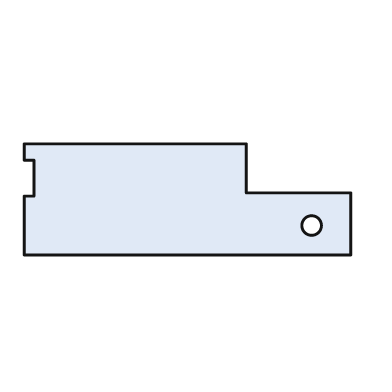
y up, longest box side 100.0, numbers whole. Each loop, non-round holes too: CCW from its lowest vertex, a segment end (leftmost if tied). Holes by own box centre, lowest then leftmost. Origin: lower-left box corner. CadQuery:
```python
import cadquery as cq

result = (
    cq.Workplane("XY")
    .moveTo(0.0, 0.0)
    .lineTo(100.0, 0.0)
    .lineTo(100.0, 19.0)
    .lineTo(68.0, 19.0)
    .lineTo(68.0, 34.0)
    .lineTo(0.0, 34.0)
    .lineTo(0.0, 29.0)
    .lineTo(3.0, 29.0)
    .lineTo(3.0, 18.0)
    .lineTo(0.0, 18.0)
    .close()
    .moveTo(88.0, 9.0)
    .circle(3.0)
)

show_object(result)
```